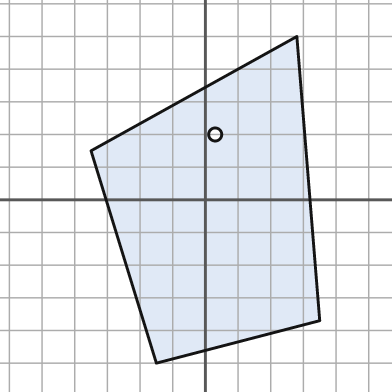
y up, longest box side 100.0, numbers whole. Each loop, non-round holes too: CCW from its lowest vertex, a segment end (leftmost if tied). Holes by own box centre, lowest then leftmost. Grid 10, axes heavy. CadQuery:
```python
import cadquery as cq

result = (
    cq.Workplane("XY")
    .moveTo(-15.0, -50.0)
    .lineTo(35.0, -37.0)
    .lineTo(28.0, 50.0)
    .lineTo(-35.0, 15.0)
    .close()
    .moveTo(3.0, 20.0)
    .circle(2.0)
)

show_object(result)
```